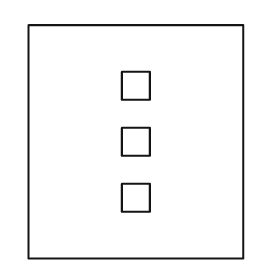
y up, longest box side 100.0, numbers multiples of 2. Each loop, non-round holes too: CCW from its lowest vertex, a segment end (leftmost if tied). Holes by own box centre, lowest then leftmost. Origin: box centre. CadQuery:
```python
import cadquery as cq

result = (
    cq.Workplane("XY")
    .moveTo(-46.0, -50.0)
    .lineTo(46.0, -50.0)
    .lineTo(46.0, 50.0)
    .lineTo(-46.0, 50.0)
    .close()
    .moveTo(-6.0, -30.0)
    .lineTo(6.0, -30.0)
    .lineTo(6.0, -18.0)
    .lineTo(-6.0, -18.0)
    .close()
    .moveTo(-6.0, -6.0)
    .lineTo(6.0, -6.0)
    .lineTo(6.0, 6.0)
    .lineTo(-6.0, 6.0)
    .close()
    .moveTo(-6.0, 18.0)
    .lineTo(6.0, 18.0)
    .lineTo(6.0, 30.0)
    .lineTo(-6.0, 30.0)
    .close()
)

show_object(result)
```